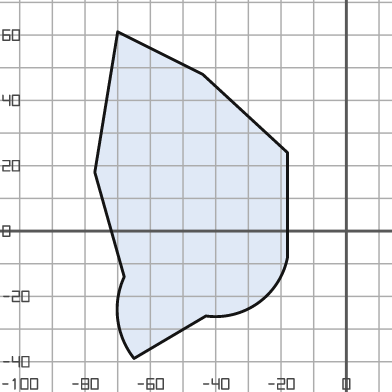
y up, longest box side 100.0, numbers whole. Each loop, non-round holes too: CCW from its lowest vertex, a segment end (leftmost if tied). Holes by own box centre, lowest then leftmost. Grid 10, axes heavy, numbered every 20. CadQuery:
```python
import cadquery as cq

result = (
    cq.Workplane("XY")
    .moveTo(-65.0, -39.0)
    .lineTo(-43.0, -26.0)
    .threePointArc((-27.0, -22.0), (-18.0, -8.0))
    .lineTo(-18.0, 24.0)
    .lineTo(-44.0, 48.0)
    .lineTo(-70.0, 61.0)
    .lineTo(-77.0, 18.0)
    .lineTo(-68.0, -14.0)
    .threePointArc((-70.0, -27.0), (-65.0, -39.0))
    .close()
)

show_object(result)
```